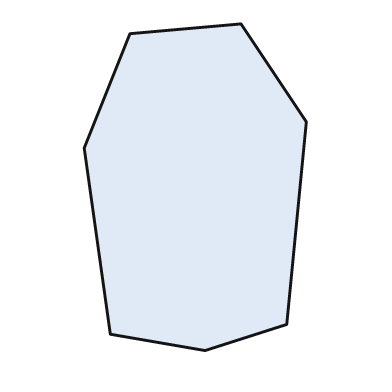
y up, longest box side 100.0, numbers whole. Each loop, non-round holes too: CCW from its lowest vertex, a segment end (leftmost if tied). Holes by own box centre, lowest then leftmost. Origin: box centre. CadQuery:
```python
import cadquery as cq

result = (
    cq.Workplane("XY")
    .moveTo(3.0, -50.0)
    .lineTo(28.0, -42.0)
    .lineTo(34.0, 20.0)
    .lineTo(14.0, 50.0)
    .lineTo(-20.0, 47.0)
    .lineTo(-34.0, 12.0)
    .lineTo(-26.0, -45.0)
    .close()
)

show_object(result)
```